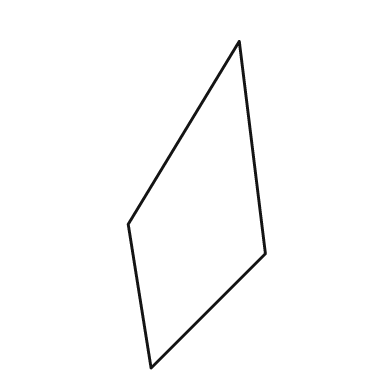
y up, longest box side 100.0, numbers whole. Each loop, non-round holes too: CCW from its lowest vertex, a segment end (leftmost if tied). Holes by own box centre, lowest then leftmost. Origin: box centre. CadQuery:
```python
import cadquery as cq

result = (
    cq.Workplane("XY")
    .moveTo(-14.0, -50.0)
    .lineTo(21.0, -15.0)
    .lineTo(13.0, 50.0)
    .lineTo(-21.0, -6.0)
    .close()
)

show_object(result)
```